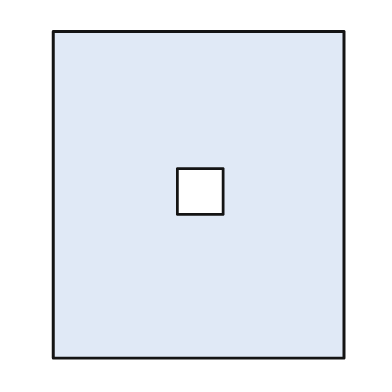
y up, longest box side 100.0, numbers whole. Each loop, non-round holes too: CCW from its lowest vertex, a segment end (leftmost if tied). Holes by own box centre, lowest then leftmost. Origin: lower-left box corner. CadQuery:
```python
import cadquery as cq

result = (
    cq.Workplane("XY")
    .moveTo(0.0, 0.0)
    .lineTo(89.0, 0.0)
    .lineTo(89.0, 100.0)
    .lineTo(0.0, 100.0)
    .close()
    .moveTo(38.0, 44.0)
    .lineTo(52.0, 44.0)
    .lineTo(52.0, 58.0)
    .lineTo(38.0, 58.0)
    .close()
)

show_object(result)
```